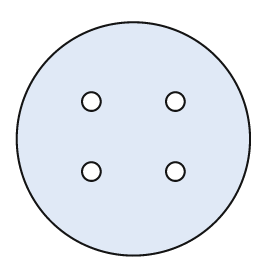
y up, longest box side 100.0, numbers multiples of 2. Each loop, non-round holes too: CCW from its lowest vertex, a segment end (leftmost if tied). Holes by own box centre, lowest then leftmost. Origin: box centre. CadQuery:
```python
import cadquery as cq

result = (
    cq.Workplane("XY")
    .moveTo(0.0, 0.0)
    .circle(50.0)
    .moveTo(-18.0, -14.0)
    .circle(4.0)
    .moveTo(18.0, -14.0)
    .circle(4.0)
    .moveTo(-18.0, 16.0)
    .circle(4.0)
    .moveTo(18.0, 16.0)
    .circle(4.0)
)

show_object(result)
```